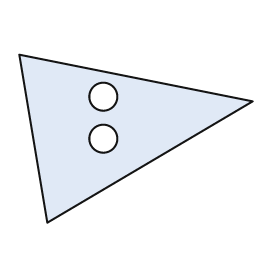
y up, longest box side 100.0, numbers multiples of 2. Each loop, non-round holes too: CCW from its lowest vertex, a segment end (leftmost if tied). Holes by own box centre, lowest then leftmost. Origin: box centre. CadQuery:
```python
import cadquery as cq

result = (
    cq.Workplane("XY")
    .moveTo(-38.0, -36.0)
    .lineTo(50.0, 16.0)
    .lineTo(-50.0, 36.0)
    .close()
    .moveTo(-14.0, 0.0)
    .circle(6.0)
    .moveTo(-14.0, 18.0)
    .circle(6.0)
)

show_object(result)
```